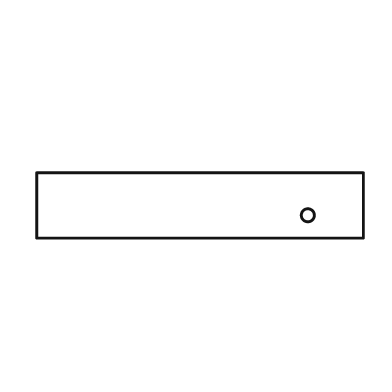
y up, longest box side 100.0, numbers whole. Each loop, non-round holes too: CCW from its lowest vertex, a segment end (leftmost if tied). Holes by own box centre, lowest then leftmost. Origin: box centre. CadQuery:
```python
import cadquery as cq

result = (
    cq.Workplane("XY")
    .moveTo(-50.0, -10.0)
    .lineTo(50.0, -10.0)
    .lineTo(50.0, 10.0)
    .lineTo(-50.0, 10.0)
    .close()
    .moveTo(33.0, -3.0)
    .circle(2.0)
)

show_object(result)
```